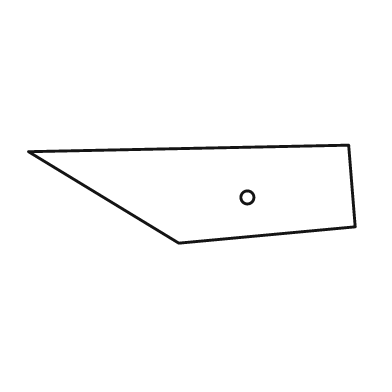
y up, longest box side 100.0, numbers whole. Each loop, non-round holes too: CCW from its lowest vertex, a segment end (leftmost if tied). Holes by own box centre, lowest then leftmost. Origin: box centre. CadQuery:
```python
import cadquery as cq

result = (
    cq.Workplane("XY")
    .moveTo(-4.0, -15.0)
    .lineTo(50.0, -10.0)
    .lineTo(48.0, 15.0)
    .lineTo(-50.0, 13.0)
    .close()
    .moveTo(17.0, -1.0)
    .circle(2.0)
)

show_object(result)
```